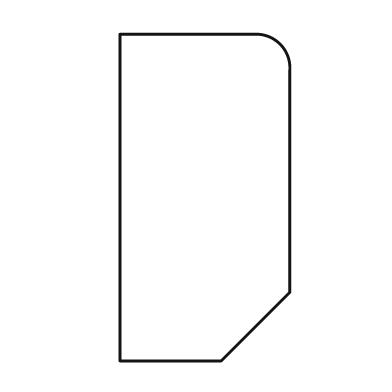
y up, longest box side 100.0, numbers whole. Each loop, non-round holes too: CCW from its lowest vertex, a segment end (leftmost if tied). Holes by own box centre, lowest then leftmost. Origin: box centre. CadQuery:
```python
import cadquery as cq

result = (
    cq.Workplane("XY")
    .moveTo(-26.0, -50.0)
    .lineTo(5.0, -50.0)
    .lineTo(26.0, -29.0)
    .lineTo(26.0, 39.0)
    .threePointArc((23.0, 47.0), (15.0, 50.0))
    .lineTo(-26.0, 50.0)
    .close()
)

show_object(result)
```